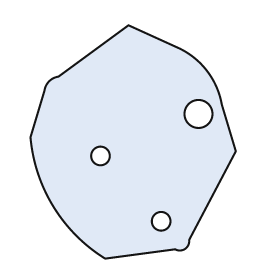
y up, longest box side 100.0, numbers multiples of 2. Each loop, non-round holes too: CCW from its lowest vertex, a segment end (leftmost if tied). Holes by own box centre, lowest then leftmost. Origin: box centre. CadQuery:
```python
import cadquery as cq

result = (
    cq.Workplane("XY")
    .moveTo(-12.0, -50.0)
    .lineTo(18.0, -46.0)
    .threePointArc((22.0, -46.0), (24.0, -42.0))
    .lineTo(44.0, -4.0)
    .lineTo(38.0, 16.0)
    .threePointArc((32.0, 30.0), (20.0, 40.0))
    .lineTo(-2.0, 50.0)
    .lineTo(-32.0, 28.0)
    .threePointArc((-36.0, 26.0), (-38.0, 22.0))
    .lineTo(-44.0, 2.0)
    .threePointArc((-34.0, -28.0), (-12.0, -50.0))
    .close()
    .moveTo(12.0, -34.0)
    .circle(4.0)
    .moveTo(-14.0, -6.0)
    .circle(4.0)
    .moveTo(28.0, 12.0)
    .circle(6.0)
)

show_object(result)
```